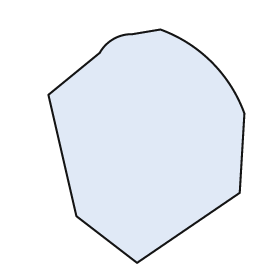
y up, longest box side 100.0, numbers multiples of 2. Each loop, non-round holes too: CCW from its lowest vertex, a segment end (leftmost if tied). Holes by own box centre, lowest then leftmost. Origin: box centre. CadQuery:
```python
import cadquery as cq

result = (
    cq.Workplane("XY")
    .moveTo(-4.0, -50.0)
    .lineTo(40.0, -20.0)
    .lineTo(42.0, 14.0)
    .threePointArc((28.0, 36.0), (6.0, 50.0))
    .lineTo(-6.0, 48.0)
    .threePointArc((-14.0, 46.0), (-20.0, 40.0))
    .lineTo(-42.0, 22.0)
    .lineTo(-30.0, -30.0)
    .close()
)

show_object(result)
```